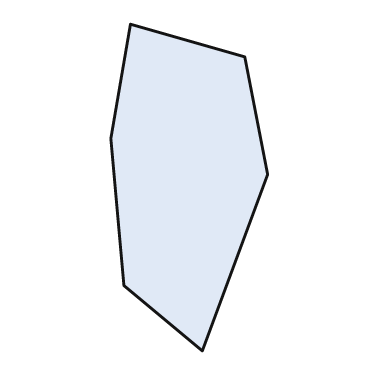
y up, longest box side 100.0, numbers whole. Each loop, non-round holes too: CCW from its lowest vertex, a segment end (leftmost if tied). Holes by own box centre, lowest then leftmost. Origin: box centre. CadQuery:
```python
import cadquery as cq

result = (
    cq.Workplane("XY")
    .moveTo(4.0, -50.0)
    .lineTo(24.0, 4.0)
    .lineTo(17.0, 40.0)
    .lineTo(-18.0, 50.0)
    .lineTo(-24.0, 15.0)
    .lineTo(-20.0, -30.0)
    .close()
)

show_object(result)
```